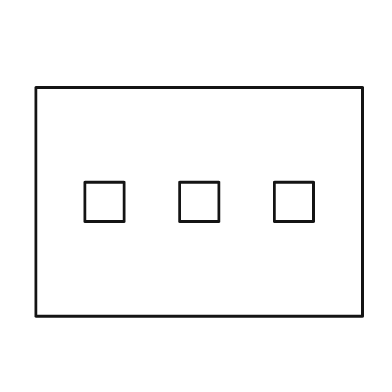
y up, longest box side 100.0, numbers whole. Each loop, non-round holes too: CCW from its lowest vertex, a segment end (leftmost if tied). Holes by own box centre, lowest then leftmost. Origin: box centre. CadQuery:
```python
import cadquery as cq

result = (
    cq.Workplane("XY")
    .moveTo(-50.0, -35.0)
    .lineTo(50.0, -35.0)
    .lineTo(50.0, 35.0)
    .lineTo(-50.0, 35.0)
    .close()
    .moveTo(-35.0, -6.0)
    .lineTo(-23.0, -6.0)
    .lineTo(-23.0, 6.0)
    .lineTo(-35.0, 6.0)
    .close()
    .moveTo(-6.0, -6.0)
    .lineTo(6.0, -6.0)
    .lineTo(6.0, 6.0)
    .lineTo(-6.0, 6.0)
    .close()
    .moveTo(23.0, -6.0)
    .lineTo(35.0, -6.0)
    .lineTo(35.0, 6.0)
    .lineTo(23.0, 6.0)
    .close()
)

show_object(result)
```